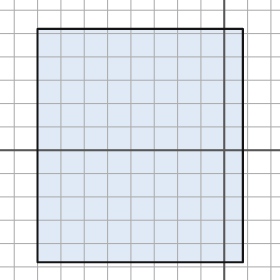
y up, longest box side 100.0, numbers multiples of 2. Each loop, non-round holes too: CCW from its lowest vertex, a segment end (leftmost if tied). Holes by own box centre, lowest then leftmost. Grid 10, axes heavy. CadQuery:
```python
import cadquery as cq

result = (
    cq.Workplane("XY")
    .moveTo(-80.0, -48.0)
    .lineTo(8.0, -48.0)
    .lineTo(8.0, 52.0)
    .lineTo(-80.0, 52.0)
    .close()
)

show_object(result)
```